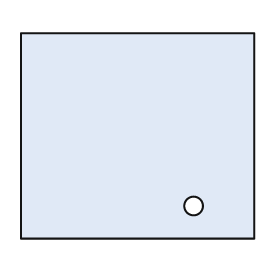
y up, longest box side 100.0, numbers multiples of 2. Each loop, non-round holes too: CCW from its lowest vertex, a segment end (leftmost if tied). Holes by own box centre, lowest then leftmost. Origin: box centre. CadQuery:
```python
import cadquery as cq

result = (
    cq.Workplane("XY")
    .moveTo(-50.0, -44.0)
    .lineTo(50.0, -44.0)
    .lineTo(50.0, 44.0)
    .lineTo(-50.0, 44.0)
    .close()
    .moveTo(24.0, -30.0)
    .circle(4.0)
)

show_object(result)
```